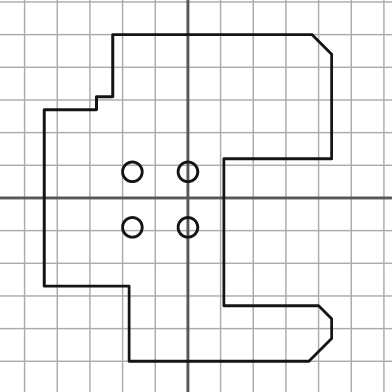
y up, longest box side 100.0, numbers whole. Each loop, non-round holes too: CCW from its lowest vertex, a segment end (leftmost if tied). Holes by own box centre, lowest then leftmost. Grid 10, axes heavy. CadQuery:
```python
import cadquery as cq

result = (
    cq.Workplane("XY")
    .moveTo(-18.0, -50.0)
    .lineTo(37.0, -50.0)
    .lineTo(44.0, -43.0)
    .lineTo(44.0, -37.0)
    .lineTo(40.0, -33.0)
    .lineTo(11.0, -33.0)
    .lineTo(11.0, 12.0)
    .lineTo(44.0, 12.0)
    .lineTo(44.0, 44.0)
    .lineTo(38.0, 50.0)
    .lineTo(-23.0, 50.0)
    .lineTo(-23.0, 31.0)
    .lineTo(-28.0, 31.0)
    .lineTo(-28.0, 27.0)
    .lineTo(-44.0, 27.0)
    .lineTo(-44.0, -27.0)
    .lineTo(-18.0, -27.0)
    .close()
    .moveTo(-17.0, -9.0)
    .circle(3.0)
    .moveTo(0.0, -9.0)
    .circle(3.0)
    .moveTo(-17.0, 8.0)
    .circle(3.0)
    .moveTo(0.0, 8.0)
    .circle(3.0)
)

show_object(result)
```